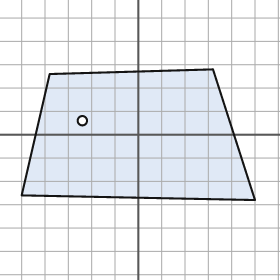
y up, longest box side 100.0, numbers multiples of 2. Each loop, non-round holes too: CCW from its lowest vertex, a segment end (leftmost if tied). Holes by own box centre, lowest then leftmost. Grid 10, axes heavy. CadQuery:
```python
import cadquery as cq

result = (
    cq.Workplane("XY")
    .moveTo(50.0, -28.0)
    .lineTo(32.0, 28.0)
    .lineTo(-38.0, 26.0)
    .lineTo(-50.0, -26.0)
    .close()
    .moveTo(-24.0, 6.0)
    .circle(2.0)
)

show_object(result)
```